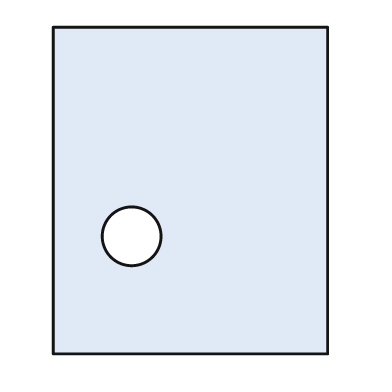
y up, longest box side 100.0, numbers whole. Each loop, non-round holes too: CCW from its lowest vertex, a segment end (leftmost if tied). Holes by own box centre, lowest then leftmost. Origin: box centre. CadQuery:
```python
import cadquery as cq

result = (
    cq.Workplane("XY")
    .moveTo(-42.0, -50.0)
    .lineTo(42.0, -50.0)
    .lineTo(42.0, 50.0)
    .lineTo(-42.0, 50.0)
    .close()
    .moveTo(-18.0, -14.0)
    .circle(9.0)
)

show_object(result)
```